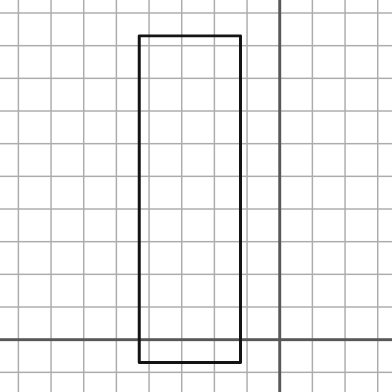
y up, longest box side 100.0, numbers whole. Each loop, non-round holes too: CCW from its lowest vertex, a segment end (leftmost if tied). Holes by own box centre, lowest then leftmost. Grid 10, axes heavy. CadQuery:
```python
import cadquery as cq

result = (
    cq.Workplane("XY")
    .moveTo(-43.0, -7.0)
    .lineTo(-12.0, -7.0)
    .lineTo(-12.0, 93.0)
    .lineTo(-43.0, 93.0)
    .close()
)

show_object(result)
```